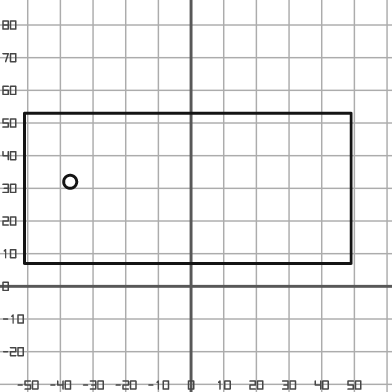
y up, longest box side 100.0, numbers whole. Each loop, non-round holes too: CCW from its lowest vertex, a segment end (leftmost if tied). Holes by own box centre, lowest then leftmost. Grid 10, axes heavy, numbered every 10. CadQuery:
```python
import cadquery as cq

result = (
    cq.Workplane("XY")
    .moveTo(-51.0, 7.0)
    .lineTo(49.0, 7.0)
    .lineTo(49.0, 53.0)
    .lineTo(-51.0, 53.0)
    .close()
    .moveTo(-37.0, 32.0)
    .circle(2.0)
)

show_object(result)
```